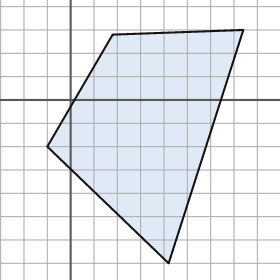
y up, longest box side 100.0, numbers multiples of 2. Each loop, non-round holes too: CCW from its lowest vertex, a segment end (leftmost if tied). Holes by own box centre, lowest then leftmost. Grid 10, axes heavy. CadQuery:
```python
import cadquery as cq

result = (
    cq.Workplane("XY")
    .moveTo(42.0, -70.0)
    .lineTo(74.0, 30.0)
    .lineTo(18.0, 28.0)
    .lineTo(-10.0, -20.0)
    .close()
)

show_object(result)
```